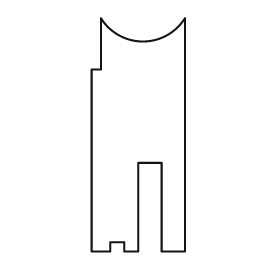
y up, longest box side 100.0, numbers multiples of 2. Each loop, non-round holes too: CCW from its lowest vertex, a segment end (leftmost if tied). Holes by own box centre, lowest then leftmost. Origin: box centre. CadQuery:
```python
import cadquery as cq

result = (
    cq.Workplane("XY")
    .moveTo(-20.0, -50.0)
    .lineTo(-12.0, -50.0)
    .lineTo(-12.0, -46.0)
    .lineTo(-6.0, -46.0)
    .lineTo(-6.0, -50.0)
    .lineTo(0.0, -50.0)
    .lineTo(0.0, -12.0)
    .lineTo(10.0, -12.0)
    .lineTo(10.0, -50.0)
    .lineTo(20.0, -50.0)
    .lineTo(20.0, 50.0)
    .threePointArc((2.0, 40.0), (-16.0, 50.0))
    .lineTo(-16.0, 28.0)
    .lineTo(-20.0, 28.0)
    .close()
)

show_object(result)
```